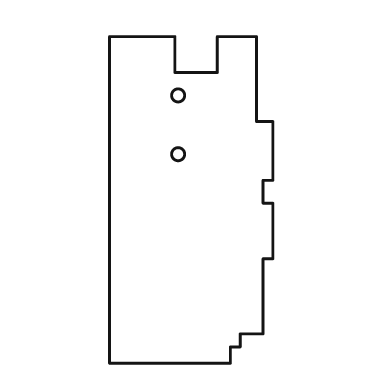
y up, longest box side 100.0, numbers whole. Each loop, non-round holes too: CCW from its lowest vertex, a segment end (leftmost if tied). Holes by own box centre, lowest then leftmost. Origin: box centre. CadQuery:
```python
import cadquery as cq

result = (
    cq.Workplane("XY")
    .moveTo(-25.0, -50.0)
    .lineTo(12.0, -50.0)
    .lineTo(12.0, -45.0)
    .lineTo(15.0, -45.0)
    .lineTo(15.0, -41.0)
    .lineTo(22.0, -41.0)
    .lineTo(22.0, -18.0)
    .lineTo(25.0, -18.0)
    .lineTo(25.0, -1.0)
    .lineTo(22.0, -1.0)
    .lineTo(22.0, 6.0)
    .lineTo(25.0, 6.0)
    .lineTo(25.0, 24.0)
    .lineTo(20.0, 24.0)
    .lineTo(20.0, 50.0)
    .lineTo(8.0, 50.0)
    .lineTo(8.0, 39.0)
    .lineTo(-5.0, 39.0)
    .lineTo(-5.0, 50.0)
    .lineTo(-25.0, 50.0)
    .close()
    .moveTo(-4.0, 14.0)
    .circle(2.0)
    .moveTo(-4.0, 32.0)
    .circle(2.0)
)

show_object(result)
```